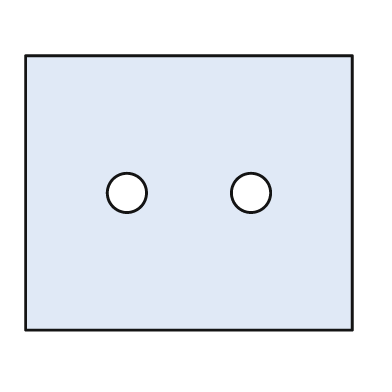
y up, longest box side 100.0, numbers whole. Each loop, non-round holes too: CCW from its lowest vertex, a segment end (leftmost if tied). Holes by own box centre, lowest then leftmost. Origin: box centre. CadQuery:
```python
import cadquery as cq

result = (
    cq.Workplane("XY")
    .moveTo(-50.0, -42.0)
    .lineTo(50.0, -42.0)
    .lineTo(50.0, 42.0)
    .lineTo(-50.0, 42.0)
    .close()
    .moveTo(-19.0, 0.0)
    .circle(6.0)
    .moveTo(19.0, 0.0)
    .circle(6.0)
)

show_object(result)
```